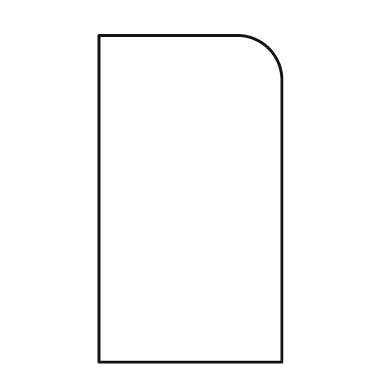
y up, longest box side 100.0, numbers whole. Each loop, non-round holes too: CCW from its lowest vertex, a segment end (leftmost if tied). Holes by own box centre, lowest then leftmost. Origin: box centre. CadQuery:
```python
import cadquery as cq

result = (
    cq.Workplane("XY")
    .moveTo(-28.0, -50.0)
    .lineTo(28.0, -50.0)
    .lineTo(28.0, 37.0)
    .threePointArc((24.0, 46.0), (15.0, 50.0))
    .lineTo(-28.0, 50.0)
    .close()
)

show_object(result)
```